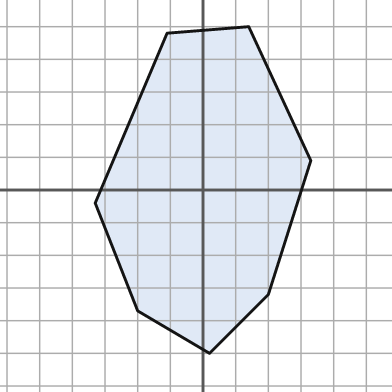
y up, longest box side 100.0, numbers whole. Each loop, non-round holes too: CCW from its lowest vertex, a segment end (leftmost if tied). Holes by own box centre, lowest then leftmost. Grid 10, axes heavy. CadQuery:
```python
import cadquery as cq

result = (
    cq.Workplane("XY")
    .moveTo(2.0, -50.0)
    .lineTo(20.0, -32.0)
    .lineTo(33.0, 9.0)
    .lineTo(14.0, 50.0)
    .lineTo(-11.0, 48.0)
    .lineTo(-33.0, -4.0)
    .lineTo(-20.0, -37.0)
    .close()
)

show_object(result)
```